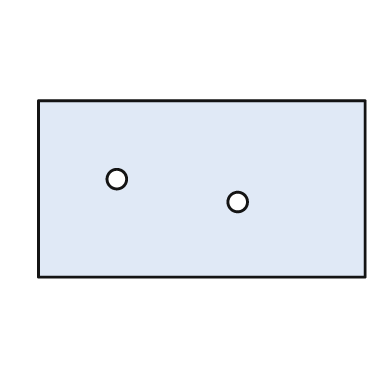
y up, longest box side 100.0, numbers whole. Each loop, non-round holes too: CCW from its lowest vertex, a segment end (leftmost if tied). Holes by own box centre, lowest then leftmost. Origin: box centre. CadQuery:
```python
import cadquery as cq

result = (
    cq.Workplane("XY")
    .moveTo(-50.0, -27.0)
    .lineTo(50.0, -27.0)
    .lineTo(50.0, 27.0)
    .lineTo(-50.0, 27.0)
    .close()
    .moveTo(11.0, -4.0)
    .circle(3.0)
    .moveTo(-26.0, 3.0)
    .circle(3.0)
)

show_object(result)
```